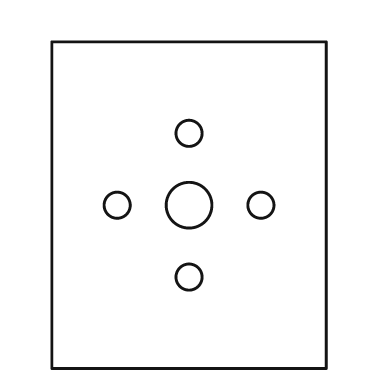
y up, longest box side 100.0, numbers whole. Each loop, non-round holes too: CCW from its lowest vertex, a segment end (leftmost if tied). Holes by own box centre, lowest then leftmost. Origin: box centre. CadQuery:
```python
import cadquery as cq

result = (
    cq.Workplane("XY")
    .moveTo(-42.0, -50.0)
    .lineTo(42.0, -50.0)
    .lineTo(42.0, 50.0)
    .lineTo(-42.0, 50.0)
    .close()
    .moveTo(0.0, -22.0)
    .circle(4.0)
    .moveTo(-22.0, 0.0)
    .circle(4.0)
    .moveTo(0.0, 0.0)
    .circle(7.0)
    .moveTo(22.0, 0.0)
    .circle(4.0)
    .moveTo(0.0, 22.0)
    .circle(4.0)
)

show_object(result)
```